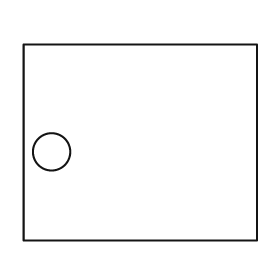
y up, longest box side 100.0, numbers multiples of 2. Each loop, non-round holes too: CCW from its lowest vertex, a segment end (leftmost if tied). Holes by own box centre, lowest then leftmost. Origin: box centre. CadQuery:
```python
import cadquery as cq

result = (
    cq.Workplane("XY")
    .moveTo(-50.0, -42.0)
    .lineTo(50.0, -42.0)
    .lineTo(50.0, 42.0)
    .lineTo(-50.0, 42.0)
    .close()
    .moveTo(-38.0, -4.0)
    .circle(8.0)
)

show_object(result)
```